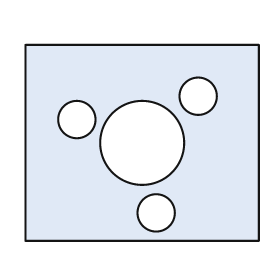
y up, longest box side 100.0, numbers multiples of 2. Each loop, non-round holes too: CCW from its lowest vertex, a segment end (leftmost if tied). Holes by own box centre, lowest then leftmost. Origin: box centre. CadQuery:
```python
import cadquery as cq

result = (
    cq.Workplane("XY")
    .moveTo(-50.0, -42.0)
    .lineTo(50.0, -42.0)
    .lineTo(50.0, 42.0)
    .lineTo(-50.0, 42.0)
    .close()
    .moveTo(6.0, -30.0)
    .circle(8.0)
    .moveTo(0.0, 0.0)
    .circle(18.0)
    .moveTo(-28.0, 10.0)
    .circle(8.0)
    .moveTo(24.0, 20.0)
    .circle(8.0)
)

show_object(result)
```